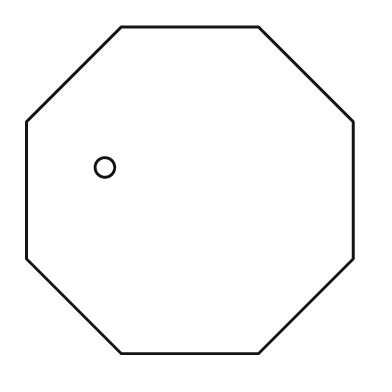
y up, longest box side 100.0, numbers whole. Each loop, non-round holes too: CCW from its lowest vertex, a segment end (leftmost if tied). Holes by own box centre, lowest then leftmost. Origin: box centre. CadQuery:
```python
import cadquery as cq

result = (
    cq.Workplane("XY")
    .moveTo(-21.0, -50.0)
    .lineTo(21.0, -50.0)
    .lineTo(50.0, -21.0)
    .lineTo(50.0, 21.0)
    .lineTo(21.0, 50.0)
    .lineTo(-21.0, 50.0)
    .lineTo(-50.0, 21.0)
    .lineTo(-50.0, -21.0)
    .close()
    .moveTo(-26.0, 7.0)
    .circle(3.0)
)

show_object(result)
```